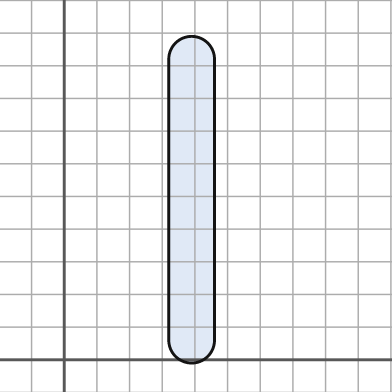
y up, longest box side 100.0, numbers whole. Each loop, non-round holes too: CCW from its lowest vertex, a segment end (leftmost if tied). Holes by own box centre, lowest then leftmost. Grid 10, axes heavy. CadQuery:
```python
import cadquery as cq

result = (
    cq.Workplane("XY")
    .moveTo(32.0, 6.0)
    .threePointArc((39.0, -1.0), (46.0, 6.0))
    .lineTo(46.0, 92.0)
    .threePointArc((39.0, 99.0), (32.0, 92.0))
    .close()
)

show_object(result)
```